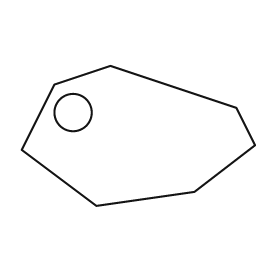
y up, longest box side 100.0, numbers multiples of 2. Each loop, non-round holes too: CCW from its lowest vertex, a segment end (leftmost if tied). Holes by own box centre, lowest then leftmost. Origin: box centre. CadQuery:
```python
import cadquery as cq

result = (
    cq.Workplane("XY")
    .moveTo(-18.0, -30.0)
    .lineTo(24.0, -24.0)
    .lineTo(50.0, -4.0)
    .lineTo(42.0, 12.0)
    .lineTo(-12.0, 30.0)
    .lineTo(-36.0, 22.0)
    .lineTo(-50.0, -6.0)
    .close()
    .moveTo(-28.0, 10.0)
    .circle(8.0)
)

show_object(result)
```